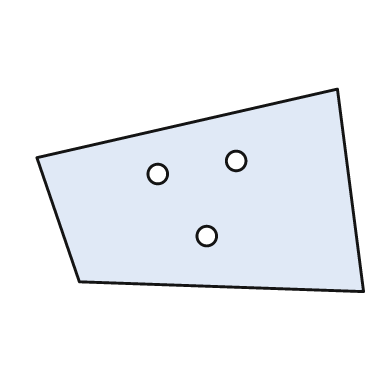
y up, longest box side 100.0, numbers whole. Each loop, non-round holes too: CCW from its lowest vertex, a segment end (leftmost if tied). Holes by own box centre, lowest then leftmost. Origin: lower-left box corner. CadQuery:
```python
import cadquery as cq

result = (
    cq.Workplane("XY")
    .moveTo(100.0, 0.0)
    .lineTo(92.0, 62.0)
    .lineTo(0.0, 41.0)
    .lineTo(13.0, 3.0)
    .close()
    .moveTo(52.0, 17.0)
    .circle(3.0)
    .moveTo(37.0, 36.0)
    .circle(3.0)
    .moveTo(61.0, 40.0)
    .circle(3.0)
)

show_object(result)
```